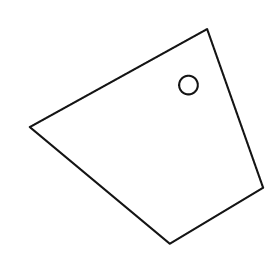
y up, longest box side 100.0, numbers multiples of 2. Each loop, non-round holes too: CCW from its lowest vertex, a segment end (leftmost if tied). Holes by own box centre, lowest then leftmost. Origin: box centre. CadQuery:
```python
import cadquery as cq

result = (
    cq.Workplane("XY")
    .moveTo(10.0, -46.0)
    .lineTo(50.0, -22.0)
    .lineTo(26.0, 46.0)
    .lineTo(-50.0, 4.0)
    .close()
    .moveTo(18.0, 22.0)
    .circle(4.0)
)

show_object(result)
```